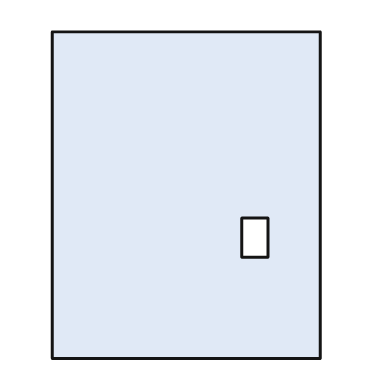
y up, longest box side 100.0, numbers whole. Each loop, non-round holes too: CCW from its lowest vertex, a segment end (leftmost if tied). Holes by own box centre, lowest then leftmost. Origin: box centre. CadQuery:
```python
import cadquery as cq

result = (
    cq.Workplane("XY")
    .moveTo(-41.0, -50.0)
    .lineTo(41.0, -50.0)
    .lineTo(41.0, 50.0)
    .lineTo(-41.0, 50.0)
    .close()
    .moveTo(17.0, -19.0)
    .lineTo(25.0, -19.0)
    .lineTo(25.0, -7.0)
    .lineTo(17.0, -7.0)
    .close()
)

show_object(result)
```